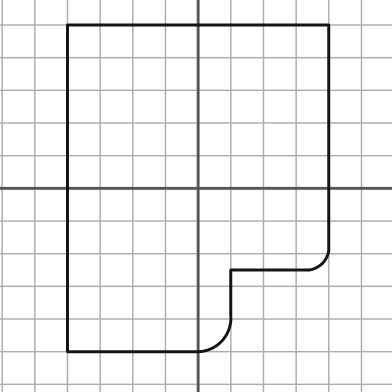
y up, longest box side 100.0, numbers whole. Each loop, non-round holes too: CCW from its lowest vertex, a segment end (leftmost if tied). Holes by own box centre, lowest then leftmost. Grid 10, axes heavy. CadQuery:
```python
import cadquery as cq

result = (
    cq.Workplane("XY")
    .moveTo(-40.0, -50.0)
    .lineTo(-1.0, -50.0)
    .threePointArc((7.0, -47.0), (10.0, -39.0))
    .lineTo(10.0, -25.0)
    .lineTo(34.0, -25.0)
    .threePointArc((38.0, -23.0), (40.0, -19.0))
    .lineTo(40.0, 50.0)
    .lineTo(-40.0, 50.0)
    .close()
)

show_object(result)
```